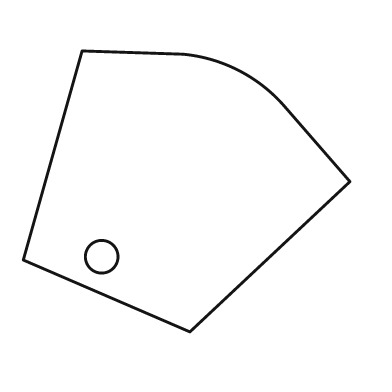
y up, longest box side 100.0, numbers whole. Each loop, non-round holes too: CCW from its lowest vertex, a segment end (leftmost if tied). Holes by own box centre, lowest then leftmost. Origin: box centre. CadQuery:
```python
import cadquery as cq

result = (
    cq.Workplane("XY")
    .moveTo(1.0, -43.0)
    .lineTo(50.0, 3.0)
    .lineTo(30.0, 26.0)
    .threePointArc((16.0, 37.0), (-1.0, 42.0))
    .lineTo(-32.0, 43.0)
    .lineTo(-50.0, -21.0)
    .close()
    .moveTo(-26.0, -20.0)
    .circle(5.0)
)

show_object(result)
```